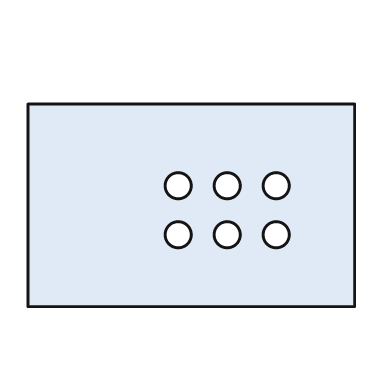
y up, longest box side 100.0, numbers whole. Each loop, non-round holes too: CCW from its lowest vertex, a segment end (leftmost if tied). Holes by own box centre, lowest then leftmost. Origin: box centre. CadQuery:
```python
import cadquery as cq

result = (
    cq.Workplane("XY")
    .moveTo(-50.0, -31.0)
    .lineTo(50.0, -31.0)
    .lineTo(50.0, 31.0)
    .lineTo(-50.0, 31.0)
    .close()
    .moveTo(-4.0, -9.0)
    .circle(4.0)
    .moveTo(11.0, -9.0)
    .circle(4.0)
    .moveTo(26.0, -9.0)
    .circle(4.0)
    .moveTo(-4.0, 6.0)
    .circle(4.0)
    .moveTo(11.0, 6.0)
    .circle(4.0)
    .moveTo(26.0, 6.0)
    .circle(4.0)
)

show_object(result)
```